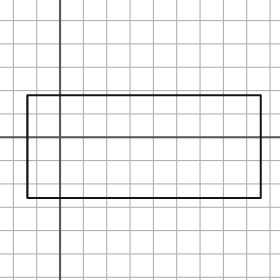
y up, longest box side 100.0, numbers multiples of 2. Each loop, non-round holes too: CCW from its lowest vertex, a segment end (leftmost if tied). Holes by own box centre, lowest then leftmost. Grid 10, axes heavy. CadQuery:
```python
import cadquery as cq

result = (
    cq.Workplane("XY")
    .moveTo(-14.0, -26.0)
    .lineTo(86.0, -26.0)
    .lineTo(86.0, 18.0)
    .lineTo(-14.0, 18.0)
    .close()
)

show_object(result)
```